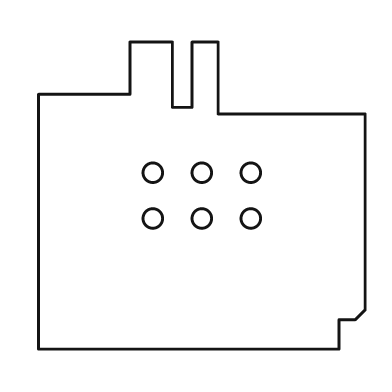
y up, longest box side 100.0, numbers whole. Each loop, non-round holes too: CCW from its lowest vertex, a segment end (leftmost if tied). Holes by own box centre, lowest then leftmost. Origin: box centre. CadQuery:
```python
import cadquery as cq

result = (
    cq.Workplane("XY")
    .moveTo(-50.0, -47.0)
    .lineTo(42.0, -47.0)
    .lineTo(42.0, -38.0)
    .lineTo(47.0, -38.0)
    .lineTo(50.0, -35.0)
    .lineTo(50.0, 25.0)
    .lineTo(5.0, 25.0)
    .lineTo(5.0, 47.0)
    .lineTo(-3.0, 47.0)
    .lineTo(-3.0, 27.0)
    .lineTo(-9.0, 27.0)
    .lineTo(-9.0, 47.0)
    .lineTo(-22.0, 47.0)
    .lineTo(-22.0, 31.0)
    .lineTo(-50.0, 31.0)
    .close()
    .moveTo(-15.0, -7.0)
    .circle(3.0)
    .moveTo(0.0, -7.0)
    .circle(3.0)
    .moveTo(15.0, -7.0)
    .circle(3.0)
    .moveTo(-15.0, 7.0)
    .circle(3.0)
    .moveTo(0.0, 7.0)
    .circle(3.0)
    .moveTo(15.0, 7.0)
    .circle(3.0)
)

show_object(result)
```